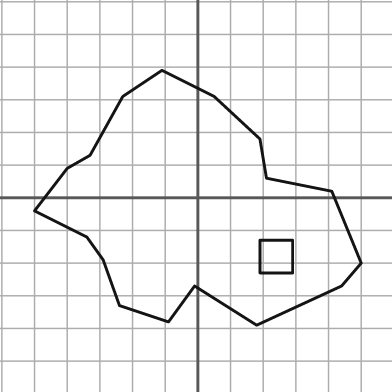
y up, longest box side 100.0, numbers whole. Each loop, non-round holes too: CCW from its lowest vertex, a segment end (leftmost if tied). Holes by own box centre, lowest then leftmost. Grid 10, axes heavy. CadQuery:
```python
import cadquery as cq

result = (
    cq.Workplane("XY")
    .moveTo(18.0, -39.0)
    .lineTo(44.0, -27.0)
    .lineTo(50.0, -20.0)
    .lineTo(41.0, 2.0)
    .lineTo(21.0, 6.0)
    .lineTo(19.0, 18.0)
    .lineTo(5.0, 31.0)
    .lineTo(-11.0, 39.0)
    .lineTo(-23.0, 31.0)
    .lineTo(-33.0, 13.0)
    .lineTo(-40.0, 9.0)
    .lineTo(-50.0, -4.0)
    .lineTo(-34.0, -12.0)
    .lineTo(-29.0, -19.0)
    .lineTo(-24.0, -33.0)
    .lineTo(-9.0, -38.0)
    .lineTo(-1.0, -27.0)
    .close()
    .moveTo(19.0, -23.0)
    .lineTo(29.0, -23.0)
    .lineTo(29.0, -13.0)
    .lineTo(19.0, -13.0)
    .close()
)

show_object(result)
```